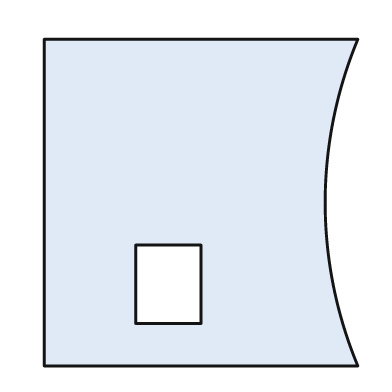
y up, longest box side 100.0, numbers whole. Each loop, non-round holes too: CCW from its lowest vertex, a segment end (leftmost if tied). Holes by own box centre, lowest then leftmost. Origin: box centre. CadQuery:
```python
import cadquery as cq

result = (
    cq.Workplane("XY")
    .moveTo(-48.0, -50.0)
    .lineTo(48.0, -50.0)
    .threePointArc((38.0, 0.0), (48.0, 50.0))
    .lineTo(-48.0, 50.0)
    .close()
    .moveTo(-20.0, -37.0)
    .lineTo(0.0, -37.0)
    .lineTo(0.0, -13.0)
    .lineTo(-20.0, -13.0)
    .close()
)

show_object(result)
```